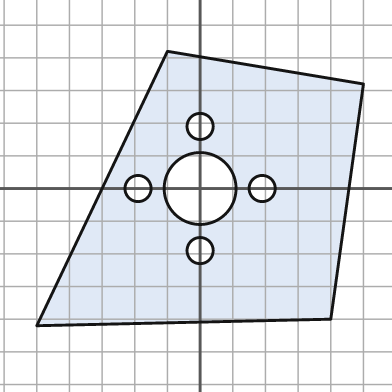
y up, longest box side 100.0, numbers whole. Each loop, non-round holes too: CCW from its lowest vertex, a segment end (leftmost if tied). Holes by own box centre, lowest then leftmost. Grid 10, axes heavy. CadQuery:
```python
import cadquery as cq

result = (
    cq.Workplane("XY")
    .moveTo(-50.0, -42.0)
    .lineTo(40.0, -40.0)
    .lineTo(50.0, 32.0)
    .lineTo(-10.0, 42.0)
    .close()
    .moveTo(0.0, -19.0)
    .circle(4.0)
    .moveTo(-19.0, 0.0)
    .circle(4.0)
    .moveTo(0.0, 0.0)
    .circle(11.0)
    .moveTo(19.0, 0.0)
    .circle(4.0)
    .moveTo(0.0, 19.0)
    .circle(4.0)
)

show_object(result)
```